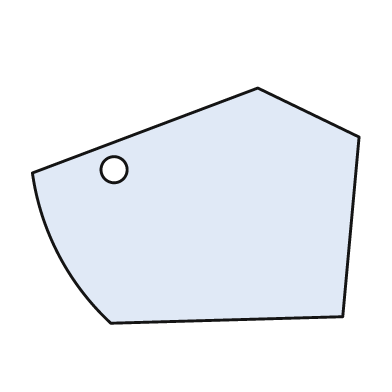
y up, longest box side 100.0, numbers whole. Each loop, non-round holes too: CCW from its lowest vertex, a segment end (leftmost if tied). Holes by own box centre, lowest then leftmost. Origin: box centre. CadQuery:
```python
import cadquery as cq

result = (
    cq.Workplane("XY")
    .moveTo(-26.0, -36.0)
    .lineTo(45.0, -34.0)
    .lineTo(50.0, 21.0)
    .lineTo(19.0, 36.0)
    .lineTo(-50.0, 10.0)
    .threePointArc((-42.0, -15.0), (-26.0, -36.0))
    .close()
    .moveTo(-25.0, 11.0)
    .circle(4.0)
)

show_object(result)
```